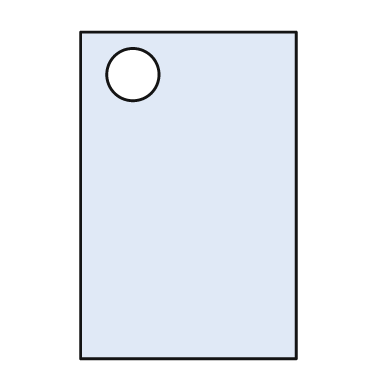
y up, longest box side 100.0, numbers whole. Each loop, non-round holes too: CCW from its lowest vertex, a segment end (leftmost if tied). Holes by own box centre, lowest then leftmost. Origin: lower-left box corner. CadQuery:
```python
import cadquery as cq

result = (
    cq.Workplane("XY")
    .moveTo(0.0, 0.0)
    .lineTo(66.0, 0.0)
    .lineTo(66.0, 100.0)
    .lineTo(0.0, 100.0)
    .close()
    .moveTo(16.0, 87.0)
    .circle(8.0)
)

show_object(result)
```